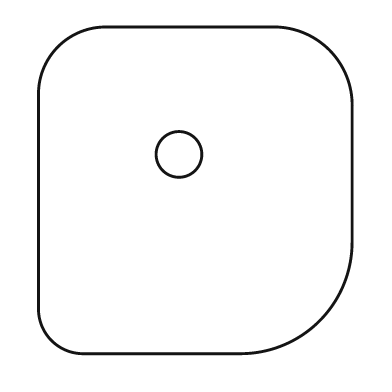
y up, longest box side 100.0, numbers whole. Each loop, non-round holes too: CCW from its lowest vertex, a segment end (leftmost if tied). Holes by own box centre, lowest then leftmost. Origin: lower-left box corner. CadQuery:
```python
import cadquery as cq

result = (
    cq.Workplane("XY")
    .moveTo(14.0, 0.0)
    .lineTo(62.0, 0.0)
    .threePointArc((86.0, 10.0), (96.0, 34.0))
    .lineTo(96.0, 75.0)
    .threePointArc((89.0, 93.0), (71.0, 100.0))
    .lineTo(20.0, 100.0)
    .threePointArc((6.0, 94.0), (0.0, 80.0))
    .lineTo(0.0, 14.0)
    .threePointArc((4.0, 4.0), (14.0, 0.0))
    .close()
    .moveTo(43.0, 61.0)
    .circle(7.0)
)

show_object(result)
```